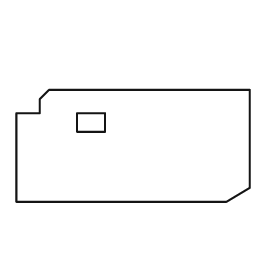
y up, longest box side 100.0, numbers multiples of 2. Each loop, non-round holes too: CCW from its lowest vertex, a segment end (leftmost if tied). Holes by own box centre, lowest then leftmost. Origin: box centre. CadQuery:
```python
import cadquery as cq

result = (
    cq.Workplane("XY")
    .moveTo(-50.0, -24.0)
    .lineTo(40.0, -24.0)
    .lineTo(50.0, -18.0)
    .lineTo(50.0, 24.0)
    .lineTo(-36.0, 24.0)
    .lineTo(-40.0, 20.0)
    .lineTo(-40.0, 14.0)
    .lineTo(-50.0, 14.0)
    .close()
    .moveTo(-24.0, 6.0)
    .lineTo(-12.0, 6.0)
    .lineTo(-12.0, 14.0)
    .lineTo(-24.0, 14.0)
    .close()
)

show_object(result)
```